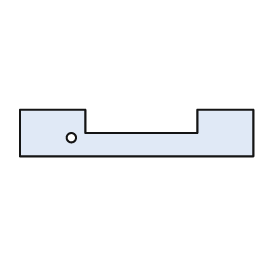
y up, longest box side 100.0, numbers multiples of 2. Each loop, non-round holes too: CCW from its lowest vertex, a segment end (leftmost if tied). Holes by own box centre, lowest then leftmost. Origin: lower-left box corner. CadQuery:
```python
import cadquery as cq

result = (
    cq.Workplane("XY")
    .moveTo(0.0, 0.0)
    .lineTo(100.0, 0.0)
    .lineTo(100.0, 20.0)
    .lineTo(76.0, 20.0)
    .lineTo(76.0, 10.0)
    .lineTo(28.0, 10.0)
    .lineTo(28.0, 20.0)
    .lineTo(0.0, 20.0)
    .close()
    .moveTo(22.0, 8.0)
    .circle(2.0)
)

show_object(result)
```